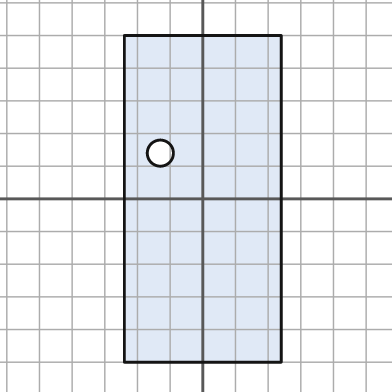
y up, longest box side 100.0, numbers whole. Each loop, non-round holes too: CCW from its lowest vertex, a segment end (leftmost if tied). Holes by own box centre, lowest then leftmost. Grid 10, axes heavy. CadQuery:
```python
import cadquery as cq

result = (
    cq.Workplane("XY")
    .moveTo(-24.0, -50.0)
    .lineTo(24.0, -50.0)
    .lineTo(24.0, 50.0)
    .lineTo(-24.0, 50.0)
    .close()
    .moveTo(-13.0, 14.0)
    .circle(4.0)
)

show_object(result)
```